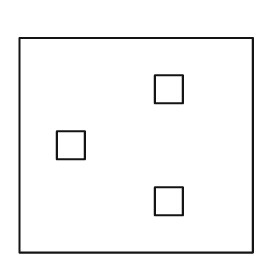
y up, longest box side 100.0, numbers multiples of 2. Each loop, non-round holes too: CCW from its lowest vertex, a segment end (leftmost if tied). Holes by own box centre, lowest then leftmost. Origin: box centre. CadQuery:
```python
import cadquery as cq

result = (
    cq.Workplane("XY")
    .moveTo(-50.0, -46.0)
    .lineTo(50.0, -46.0)
    .lineTo(50.0, 46.0)
    .lineTo(-50.0, 46.0)
    .close()
    .moveTo(8.0, -30.0)
    .lineTo(20.0, -30.0)
    .lineTo(20.0, -18.0)
    .lineTo(8.0, -18.0)
    .close()
    .moveTo(-34.0, -6.0)
    .lineTo(-22.0, -6.0)
    .lineTo(-22.0, 6.0)
    .lineTo(-34.0, 6.0)
    .close()
    .moveTo(8.0, 18.0)
    .lineTo(20.0, 18.0)
    .lineTo(20.0, 30.0)
    .lineTo(8.0, 30.0)
    .close()
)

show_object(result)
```